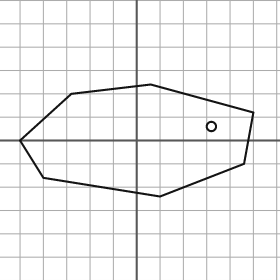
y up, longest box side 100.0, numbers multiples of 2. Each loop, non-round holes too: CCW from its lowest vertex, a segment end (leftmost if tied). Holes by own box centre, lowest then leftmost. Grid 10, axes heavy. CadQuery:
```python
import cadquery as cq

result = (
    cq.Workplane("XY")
    .moveTo(10.0, -24.0)
    .lineTo(46.0, -10.0)
    .lineTo(50.0, 12.0)
    .lineTo(6.0, 24.0)
    .lineTo(-28.0, 20.0)
    .lineTo(-50.0, 0.0)
    .lineTo(-40.0, -16.0)
    .close()
    .moveTo(32.0, 6.0)
    .circle(2.0)
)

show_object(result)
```